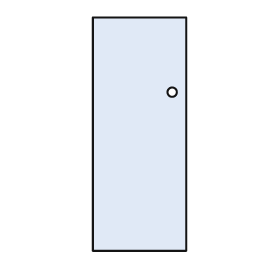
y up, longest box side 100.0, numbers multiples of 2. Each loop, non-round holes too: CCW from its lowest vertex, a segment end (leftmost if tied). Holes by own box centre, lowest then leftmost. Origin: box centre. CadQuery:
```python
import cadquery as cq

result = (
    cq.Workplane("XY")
    .moveTo(-20.0, -50.0)
    .lineTo(20.0, -50.0)
    .lineTo(20.0, 50.0)
    .lineTo(-20.0, 50.0)
    .close()
    .moveTo(14.0, 18.0)
    .circle(2.0)
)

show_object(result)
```